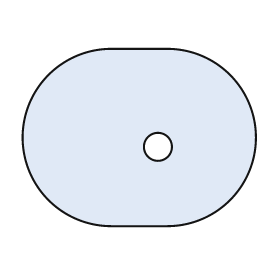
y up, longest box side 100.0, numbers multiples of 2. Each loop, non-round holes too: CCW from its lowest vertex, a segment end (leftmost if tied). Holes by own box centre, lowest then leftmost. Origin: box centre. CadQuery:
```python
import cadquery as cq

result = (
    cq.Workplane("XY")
    .moveTo(-12.0, -38.0)
    .lineTo(12.0, -38.0)
    .threePointArc((50.0, 0.0), (12.0, 38.0))
    .lineTo(-12.0, 38.0)
    .threePointArc((-50.0, 0.0), (-12.0, -38.0))
    .close()
    .moveTo(8.0, -4.0)
    .circle(6.0)
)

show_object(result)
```